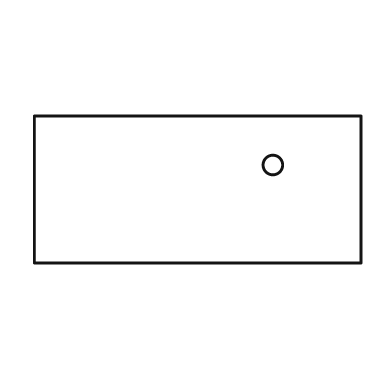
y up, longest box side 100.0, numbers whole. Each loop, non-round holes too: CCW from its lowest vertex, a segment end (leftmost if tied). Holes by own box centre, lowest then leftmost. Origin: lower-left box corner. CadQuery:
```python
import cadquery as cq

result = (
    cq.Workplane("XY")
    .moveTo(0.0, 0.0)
    .lineTo(100.0, 0.0)
    .lineTo(100.0, 45.0)
    .lineTo(0.0, 45.0)
    .close()
    .moveTo(73.0, 30.0)
    .circle(3.0)
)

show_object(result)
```